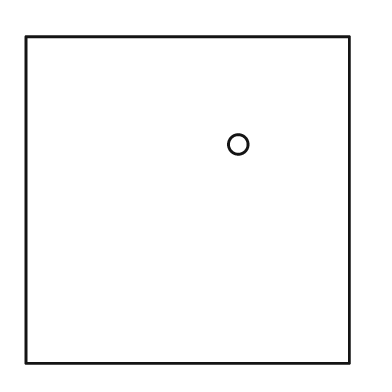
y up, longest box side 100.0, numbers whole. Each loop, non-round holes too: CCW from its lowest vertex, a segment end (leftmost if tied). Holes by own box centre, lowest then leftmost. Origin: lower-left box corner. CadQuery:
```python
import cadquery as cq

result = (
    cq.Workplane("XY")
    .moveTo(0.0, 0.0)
    .lineTo(99.0, 0.0)
    .lineTo(99.0, 100.0)
    .lineTo(0.0, 100.0)
    .close()
    .moveTo(65.0, 67.0)
    .circle(3.0)
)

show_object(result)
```